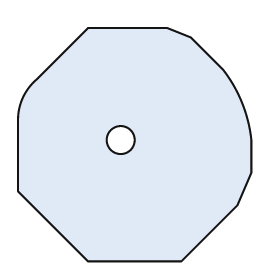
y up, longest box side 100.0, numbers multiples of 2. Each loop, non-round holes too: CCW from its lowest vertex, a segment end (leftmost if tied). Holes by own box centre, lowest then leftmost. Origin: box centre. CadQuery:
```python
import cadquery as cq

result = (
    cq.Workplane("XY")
    .moveTo(-20.0, -50.0)
    .lineTo(20.0, -50.0)
    .lineTo(44.0, -26.0)
    .lineTo(50.0, -12.0)
    .lineTo(50.0, 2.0)
    .threePointArc((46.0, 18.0), (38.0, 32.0))
    .lineTo(24.0, 46.0)
    .lineTo(14.0, 50.0)
    .lineTo(-20.0, 50.0)
    .lineTo(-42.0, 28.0)
    .threePointArc((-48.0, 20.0), (-50.0, 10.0))
    .lineTo(-50.0, -20.0)
    .close()
    .moveTo(-6.0, 2.0)
    .circle(6.0)
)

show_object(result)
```